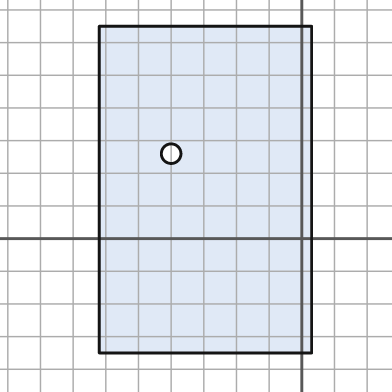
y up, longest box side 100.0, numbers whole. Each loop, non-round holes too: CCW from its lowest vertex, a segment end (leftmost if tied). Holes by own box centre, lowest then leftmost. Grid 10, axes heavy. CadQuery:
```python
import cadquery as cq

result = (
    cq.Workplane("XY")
    .moveTo(-62.0, -35.0)
    .lineTo(3.0, -35.0)
    .lineTo(3.0, 65.0)
    .lineTo(-62.0, 65.0)
    .close()
    .moveTo(-40.0, 26.0)
    .circle(3.0)
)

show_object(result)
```